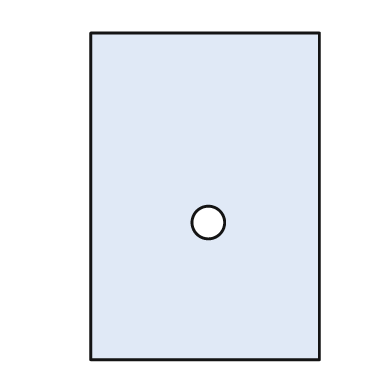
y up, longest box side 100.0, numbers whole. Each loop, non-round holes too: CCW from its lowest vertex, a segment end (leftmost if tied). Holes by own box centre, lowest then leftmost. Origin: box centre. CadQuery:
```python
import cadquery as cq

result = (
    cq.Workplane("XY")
    .moveTo(-35.0, -50.0)
    .lineTo(35.0, -50.0)
    .lineTo(35.0, 50.0)
    .lineTo(-35.0, 50.0)
    .close()
    .moveTo(1.0, -8.0)
    .circle(5.0)
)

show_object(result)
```